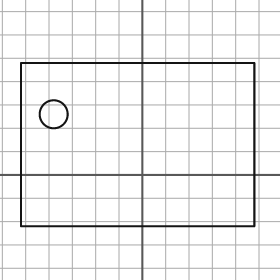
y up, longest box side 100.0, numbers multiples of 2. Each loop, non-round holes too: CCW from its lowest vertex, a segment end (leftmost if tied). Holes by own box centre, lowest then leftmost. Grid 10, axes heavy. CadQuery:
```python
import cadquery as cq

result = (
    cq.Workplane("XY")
    .moveTo(-52.0, -22.0)
    .lineTo(48.0, -22.0)
    .lineTo(48.0, 48.0)
    .lineTo(-52.0, 48.0)
    .close()
    .moveTo(-38.0, 26.0)
    .circle(6.0)
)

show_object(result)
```